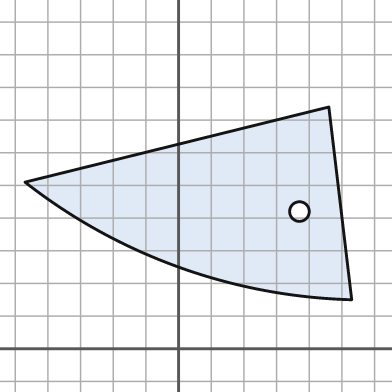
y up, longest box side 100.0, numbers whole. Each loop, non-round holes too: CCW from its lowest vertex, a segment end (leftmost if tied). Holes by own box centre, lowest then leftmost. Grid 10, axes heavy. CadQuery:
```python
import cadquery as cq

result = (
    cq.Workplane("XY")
    .moveTo(53.0, 15.0)
    .lineTo(46.0, 74.0)
    .lineTo(-47.0, 51.0)
    .threePointArc((0.0, 25.0), (53.0, 15.0))
    .close()
    .moveTo(37.0, 42.0)
    .circle(3.0)
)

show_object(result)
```